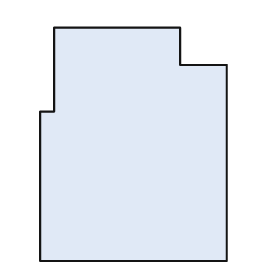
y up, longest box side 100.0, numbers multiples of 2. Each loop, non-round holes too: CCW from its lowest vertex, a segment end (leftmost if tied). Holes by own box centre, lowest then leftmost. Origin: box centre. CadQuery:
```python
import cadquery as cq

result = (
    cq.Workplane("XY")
    .moveTo(-40.0, -50.0)
    .lineTo(40.0, -50.0)
    .lineTo(40.0, 34.0)
    .lineTo(20.0, 34.0)
    .lineTo(20.0, 50.0)
    .lineTo(-34.0, 50.0)
    .lineTo(-34.0, 14.0)
    .lineTo(-40.0, 14.0)
    .close()
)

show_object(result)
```